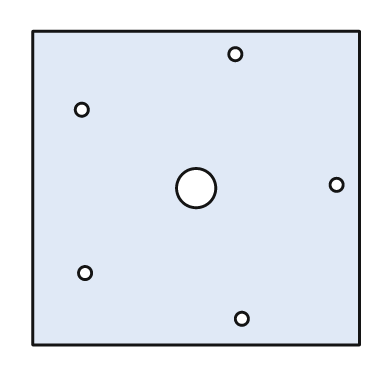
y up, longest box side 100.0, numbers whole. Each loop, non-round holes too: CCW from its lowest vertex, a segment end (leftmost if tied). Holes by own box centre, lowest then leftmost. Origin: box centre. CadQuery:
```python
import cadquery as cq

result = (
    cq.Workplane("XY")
    .moveTo(-50.0, -48.0)
    .lineTo(50.0, -48.0)
    .lineTo(50.0, 48.0)
    .lineTo(-50.0, 48.0)
    .close()
    .moveTo(14.0, -40.0)
    .circle(2.0)
    .moveTo(-34.0, -26.0)
    .circle(2.0)
    .moveTo(0.0, 0.0)
    .circle(6.0)
    .moveTo(43.0, 1.0)
    .circle(2.0)
    .moveTo(-35.0, 24.0)
    .circle(2.0)
    .moveTo(12.0, 41.0)
    .circle(2.0)
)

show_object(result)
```